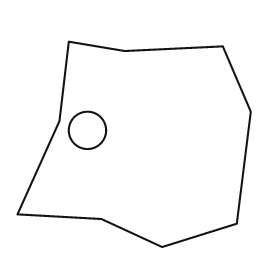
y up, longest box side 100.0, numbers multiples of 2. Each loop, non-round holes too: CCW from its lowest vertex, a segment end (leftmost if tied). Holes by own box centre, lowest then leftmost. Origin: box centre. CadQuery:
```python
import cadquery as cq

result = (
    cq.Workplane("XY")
    .moveTo(12.0, -44.0)
    .lineTo(44.0, -34.0)
    .lineTo(50.0, 14.0)
    .lineTo(38.0, 42.0)
    .lineTo(-4.0, 40.0)
    .lineTo(-28.0, 44.0)
    .lineTo(-32.0, 10.0)
    .lineTo(-50.0, -30.0)
    .lineTo(-14.0, -32.0)
    .close()
    .moveTo(-20.0, 6.0)
    .circle(8.0)
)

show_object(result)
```